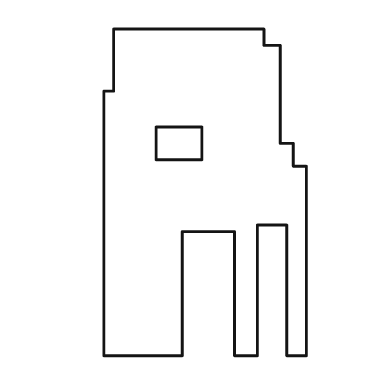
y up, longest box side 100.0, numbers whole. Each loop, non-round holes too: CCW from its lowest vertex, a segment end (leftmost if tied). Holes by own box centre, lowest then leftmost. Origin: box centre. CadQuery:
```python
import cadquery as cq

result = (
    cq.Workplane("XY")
    .moveTo(-31.0, -50.0)
    .lineTo(-7.0, -50.0)
    .lineTo(-7.0, -12.0)
    .lineTo(9.0, -12.0)
    .lineTo(9.0, -50.0)
    .lineTo(16.0, -50.0)
    .lineTo(16.0, -10.0)
    .lineTo(25.0, -10.0)
    .lineTo(25.0, -50.0)
    .lineTo(31.0, -50.0)
    .lineTo(31.0, 8.0)
    .lineTo(27.0, 8.0)
    .lineTo(27.0, 15.0)
    .lineTo(23.0, 15.0)
    .lineTo(23.0, 45.0)
    .lineTo(18.0, 45.0)
    .lineTo(18.0, 50.0)
    .lineTo(-28.0, 50.0)
    .lineTo(-28.0, 31.0)
    .lineTo(-31.0, 31.0)
    .close()
    .moveTo(-15.0, 10.0)
    .lineTo(-1.0, 10.0)
    .lineTo(-1.0, 20.0)
    .lineTo(-15.0, 20.0)
    .close()
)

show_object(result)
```